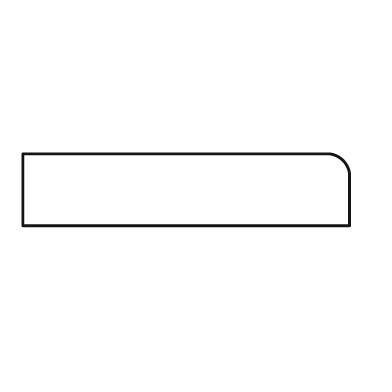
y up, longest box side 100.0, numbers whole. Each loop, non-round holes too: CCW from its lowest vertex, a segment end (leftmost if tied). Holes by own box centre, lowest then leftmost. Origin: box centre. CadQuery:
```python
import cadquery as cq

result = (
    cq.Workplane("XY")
    .moveTo(-50.0, -11.0)
    .lineTo(50.0, -11.0)
    .lineTo(50.0, 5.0)
    .threePointArc((48.0, 9.0), (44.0, 11.0))
    .lineTo(-50.0, 11.0)
    .close()
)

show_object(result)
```